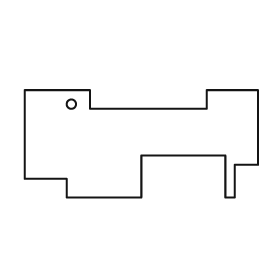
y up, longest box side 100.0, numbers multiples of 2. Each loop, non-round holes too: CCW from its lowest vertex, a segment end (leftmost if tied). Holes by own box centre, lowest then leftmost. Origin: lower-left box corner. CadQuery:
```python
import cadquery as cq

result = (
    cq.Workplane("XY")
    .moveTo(18.0, 0.0)
    .lineTo(50.0, 0.0)
    .lineTo(50.0, 18.0)
    .lineTo(86.0, 18.0)
    .lineTo(86.0, 0.0)
    .lineTo(90.0, 0.0)
    .lineTo(90.0, 14.0)
    .lineTo(100.0, 14.0)
    .lineTo(100.0, 46.0)
    .lineTo(78.0, 46.0)
    .lineTo(78.0, 38.0)
    .lineTo(28.0, 38.0)
    .lineTo(28.0, 46.0)
    .lineTo(0.0, 46.0)
    .lineTo(0.0, 8.0)
    .lineTo(18.0, 8.0)
    .close()
    .moveTo(20.0, 40.0)
    .circle(2.0)
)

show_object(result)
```